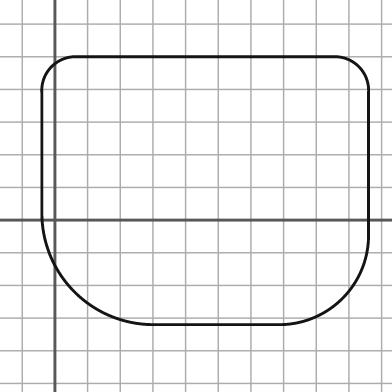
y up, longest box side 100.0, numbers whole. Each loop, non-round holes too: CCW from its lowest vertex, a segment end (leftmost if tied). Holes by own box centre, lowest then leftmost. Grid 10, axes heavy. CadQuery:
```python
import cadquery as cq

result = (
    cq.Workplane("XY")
    .moveTo(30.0, -32.0)
    .lineTo(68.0, -32.0)
    .threePointArc((88.0, -24.0), (96.0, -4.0))
    .lineTo(96.0, 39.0)
    .threePointArc((93.0, 47.0), (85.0, 50.0))
    .lineTo(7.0, 50.0)
    .threePointArc((-1.0, 47.0), (-4.0, 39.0))
    .lineTo(-4.0, 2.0)
    .threePointArc((6.0, -22.0), (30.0, -32.0))
    .close()
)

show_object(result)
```